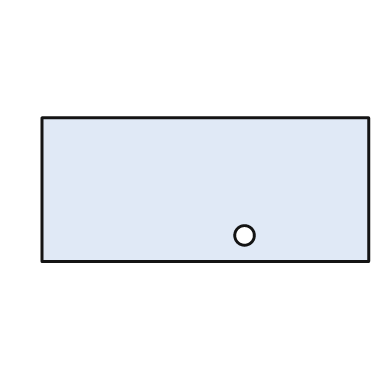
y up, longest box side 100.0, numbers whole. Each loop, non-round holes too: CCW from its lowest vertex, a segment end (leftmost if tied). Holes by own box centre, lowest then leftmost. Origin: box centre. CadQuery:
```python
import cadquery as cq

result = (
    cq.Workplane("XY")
    .moveTo(-50.0, -22.0)
    .lineTo(50.0, -22.0)
    .lineTo(50.0, 22.0)
    .lineTo(-50.0, 22.0)
    .close()
    .moveTo(12.0, -14.0)
    .circle(3.0)
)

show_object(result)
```